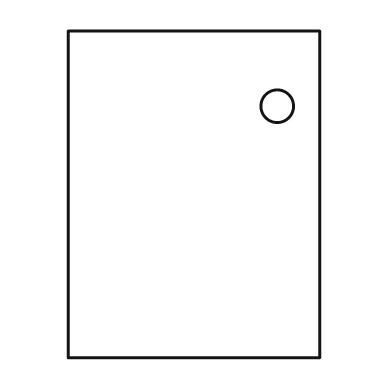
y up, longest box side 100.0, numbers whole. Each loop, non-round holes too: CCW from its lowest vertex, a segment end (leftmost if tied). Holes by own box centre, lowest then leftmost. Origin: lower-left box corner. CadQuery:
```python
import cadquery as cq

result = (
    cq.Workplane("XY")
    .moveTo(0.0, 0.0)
    .lineTo(77.0, 0.0)
    .lineTo(77.0, 100.0)
    .lineTo(0.0, 100.0)
    .close()
    .moveTo(64.0, 77.0)
    .circle(5.0)
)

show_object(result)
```